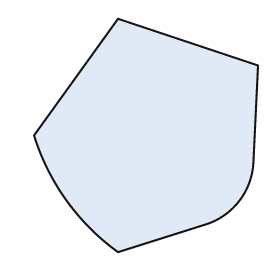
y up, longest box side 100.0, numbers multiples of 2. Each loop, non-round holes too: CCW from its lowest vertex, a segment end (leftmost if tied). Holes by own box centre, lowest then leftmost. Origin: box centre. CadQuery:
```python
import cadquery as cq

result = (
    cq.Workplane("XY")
    .moveTo(-12.0, -50.0)
    .lineTo(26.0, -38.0)
    .threePointArc((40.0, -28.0), (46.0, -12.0))
    .lineTo(48.0, 30.0)
    .lineTo(-12.0, 50.0)
    .lineTo(-48.0, 0.0)
    .threePointArc((-34.0, -28.0), (-12.0, -50.0))
    .close()
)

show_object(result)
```